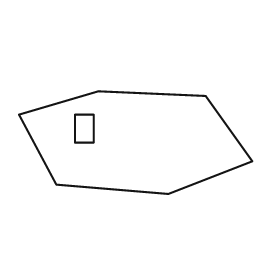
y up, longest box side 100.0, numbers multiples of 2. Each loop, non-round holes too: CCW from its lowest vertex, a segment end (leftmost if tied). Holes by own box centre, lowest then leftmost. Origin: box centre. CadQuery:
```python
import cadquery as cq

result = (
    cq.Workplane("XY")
    .moveTo(14.0, -22.0)
    .lineTo(50.0, -8.0)
    .lineTo(30.0, 20.0)
    .lineTo(-16.0, 22.0)
    .lineTo(-50.0, 12.0)
    .lineTo(-34.0, -18.0)
    .close()
    .moveTo(-26.0, 0.0)
    .lineTo(-18.0, 0.0)
    .lineTo(-18.0, 12.0)
    .lineTo(-26.0, 12.0)
    .close()
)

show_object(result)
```